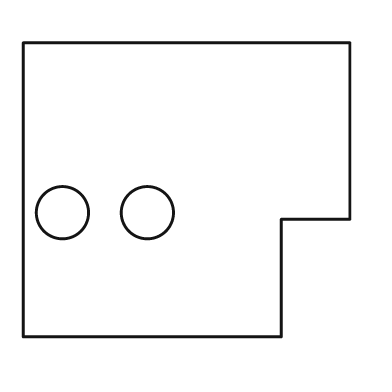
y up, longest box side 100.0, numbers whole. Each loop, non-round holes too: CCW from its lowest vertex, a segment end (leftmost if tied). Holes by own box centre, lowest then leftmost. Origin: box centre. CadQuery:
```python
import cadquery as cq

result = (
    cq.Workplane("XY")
    .moveTo(-50.0, -45.0)
    .lineTo(29.0, -45.0)
    .lineTo(29.0, -9.0)
    .lineTo(50.0, -9.0)
    .lineTo(50.0, 45.0)
    .lineTo(-50.0, 45.0)
    .close()
    .moveTo(-38.0, -7.0)
    .circle(8.0)
    .moveTo(-12.0, -7.0)
    .circle(8.0)
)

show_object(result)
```